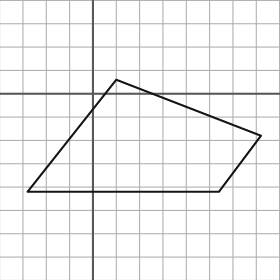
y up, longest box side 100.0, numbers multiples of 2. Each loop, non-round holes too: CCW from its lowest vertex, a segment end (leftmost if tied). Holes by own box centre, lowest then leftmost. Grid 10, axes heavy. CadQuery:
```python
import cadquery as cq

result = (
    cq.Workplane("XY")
    .moveTo(-28.0, -42.0)
    .lineTo(54.0, -42.0)
    .lineTo(72.0, -18.0)
    .lineTo(10.0, 6.0)
    .close()
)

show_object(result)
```